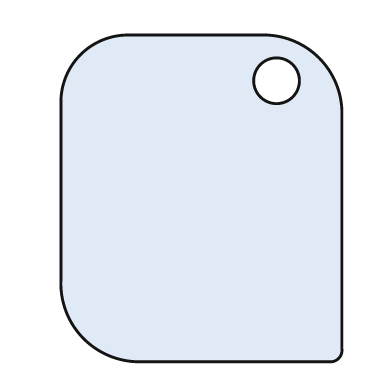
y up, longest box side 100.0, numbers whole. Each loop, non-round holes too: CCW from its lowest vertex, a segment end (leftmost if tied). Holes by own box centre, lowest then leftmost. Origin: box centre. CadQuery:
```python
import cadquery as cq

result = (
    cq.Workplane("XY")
    .moveTo(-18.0, -50.0)
    .lineTo(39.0, -50.0)
    .threePointArc((42.0, -49.0), (43.0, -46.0))
    .lineTo(43.0, 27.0)
    .threePointArc((36.0, 43.0), (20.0, 50.0))
    .lineTo(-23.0, 50.0)
    .threePointArc((-37.0, 44.0), (-43.0, 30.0))
    .lineTo(-43.0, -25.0)
    .threePointArc((-36.0, -43.0), (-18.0, -50.0))
    .close()
    .moveTo(23.0, 36.0)
    .circle(7.0)
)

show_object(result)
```